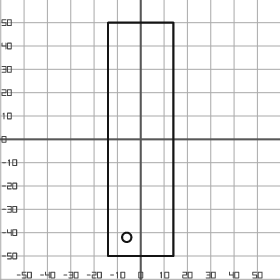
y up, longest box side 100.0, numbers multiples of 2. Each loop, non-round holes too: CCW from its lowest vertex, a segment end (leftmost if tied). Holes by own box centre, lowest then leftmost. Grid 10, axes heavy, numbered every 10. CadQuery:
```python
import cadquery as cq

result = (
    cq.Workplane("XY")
    .moveTo(-14.0, -50.0)
    .lineTo(14.0, -50.0)
    .lineTo(14.0, 50.0)
    .lineTo(-14.0, 50.0)
    .close()
    .moveTo(-6.0, -42.0)
    .circle(2.0)
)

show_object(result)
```